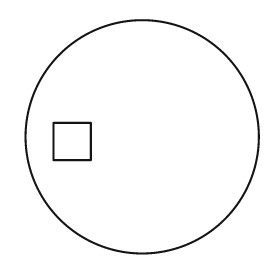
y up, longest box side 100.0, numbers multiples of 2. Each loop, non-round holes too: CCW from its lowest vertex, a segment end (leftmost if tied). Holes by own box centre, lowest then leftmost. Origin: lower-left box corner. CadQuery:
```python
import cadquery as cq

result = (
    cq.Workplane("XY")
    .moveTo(50.0, 50.0)
    .circle(50.0)
    .moveTo(12.0, 40.0)
    .lineTo(28.0, 40.0)
    .lineTo(28.0, 56.0)
    .lineTo(12.0, 56.0)
    .close()
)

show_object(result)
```